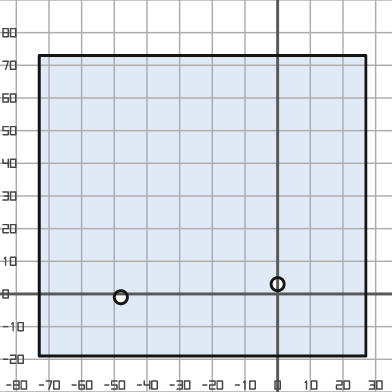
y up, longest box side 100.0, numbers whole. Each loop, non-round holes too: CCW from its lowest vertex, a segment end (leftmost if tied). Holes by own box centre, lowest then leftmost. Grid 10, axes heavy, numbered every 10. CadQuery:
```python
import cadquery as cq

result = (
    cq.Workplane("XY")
    .moveTo(-73.0, -19.0)
    .lineTo(27.0, -19.0)
    .lineTo(27.0, 73.0)
    .lineTo(-73.0, 73.0)
    .close()
    .moveTo(-48.0, -1.0)
    .circle(2.0)
    .moveTo(0.0, 3.0)
    .circle(2.0)
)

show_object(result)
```